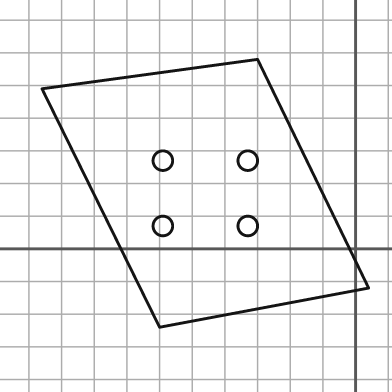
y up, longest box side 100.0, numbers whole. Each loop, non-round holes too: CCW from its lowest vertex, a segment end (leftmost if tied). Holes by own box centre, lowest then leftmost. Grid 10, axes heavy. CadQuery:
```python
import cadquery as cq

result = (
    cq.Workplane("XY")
    .moveTo(-60.0, -24.0)
    .lineTo(4.0, -12.0)
    .lineTo(-30.0, 58.0)
    .lineTo(-96.0, 49.0)
    .close()
    .moveTo(-59.0, 7.0)
    .circle(3.0)
    .moveTo(-33.0, 7.0)
    .circle(3.0)
    .moveTo(-59.0, 27.0)
    .circle(3.0)
    .moveTo(-33.0, 27.0)
    .circle(3.0)
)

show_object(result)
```